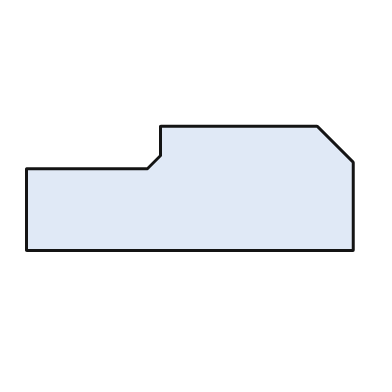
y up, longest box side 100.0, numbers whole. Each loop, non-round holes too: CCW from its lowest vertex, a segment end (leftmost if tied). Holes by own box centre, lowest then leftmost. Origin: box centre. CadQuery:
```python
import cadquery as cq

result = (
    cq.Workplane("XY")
    .moveTo(-50.0, -19.0)
    .lineTo(50.0, -19.0)
    .lineTo(50.0, 8.0)
    .lineTo(39.0, 19.0)
    .lineTo(-9.0, 19.0)
    .lineTo(-9.0, 10.0)
    .lineTo(-13.0, 6.0)
    .lineTo(-50.0, 6.0)
    .close()
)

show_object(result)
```